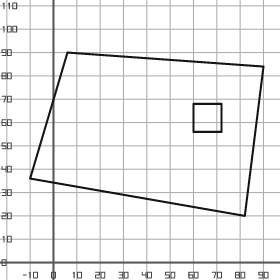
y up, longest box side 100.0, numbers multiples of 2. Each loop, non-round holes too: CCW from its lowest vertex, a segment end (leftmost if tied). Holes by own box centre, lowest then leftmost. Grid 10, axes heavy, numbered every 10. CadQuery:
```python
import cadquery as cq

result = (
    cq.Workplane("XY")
    .moveTo(82.0, 20.0)
    .lineTo(90.0, 84.0)
    .lineTo(6.0, 90.0)
    .lineTo(-10.0, 36.0)
    .close()
    .moveTo(60.0, 56.0)
    .lineTo(72.0, 56.0)
    .lineTo(72.0, 68.0)
    .lineTo(60.0, 68.0)
    .close()
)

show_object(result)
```